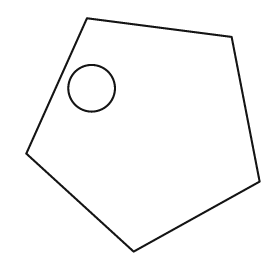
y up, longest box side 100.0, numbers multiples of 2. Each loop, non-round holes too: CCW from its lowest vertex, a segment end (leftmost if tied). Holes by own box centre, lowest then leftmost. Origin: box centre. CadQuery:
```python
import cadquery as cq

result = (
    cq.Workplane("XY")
    .moveTo(-4.0, -50.0)
    .lineTo(50.0, -20.0)
    .lineTo(38.0, 42.0)
    .lineTo(-24.0, 50.0)
    .lineTo(-50.0, -8.0)
    .close()
    .moveTo(-22.0, 20.0)
    .circle(10.0)
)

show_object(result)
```